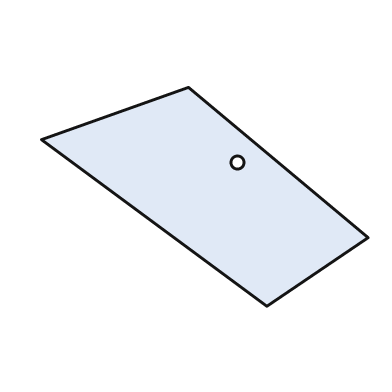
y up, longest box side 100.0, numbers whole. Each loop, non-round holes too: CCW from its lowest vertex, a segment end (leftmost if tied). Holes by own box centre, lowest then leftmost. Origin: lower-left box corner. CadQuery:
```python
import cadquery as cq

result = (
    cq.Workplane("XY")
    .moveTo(69.0, 0.0)
    .lineTo(100.0, 21.0)
    .lineTo(45.0, 67.0)
    .lineTo(0.0, 51.0)
    .close()
    .moveTo(60.0, 44.0)
    .circle(2.0)
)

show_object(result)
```